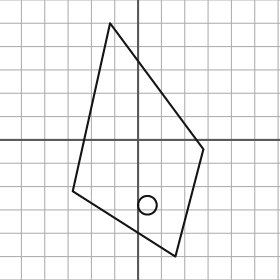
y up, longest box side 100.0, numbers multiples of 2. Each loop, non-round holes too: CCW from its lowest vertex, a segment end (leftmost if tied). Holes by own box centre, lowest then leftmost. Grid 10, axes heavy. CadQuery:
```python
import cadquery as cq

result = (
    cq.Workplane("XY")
    .moveTo(16.0, -50.0)
    .lineTo(28.0, -4.0)
    .lineTo(-12.0, 50.0)
    .lineTo(-28.0, -22.0)
    .close()
    .moveTo(4.0, -28.0)
    .circle(4.0)
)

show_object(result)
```